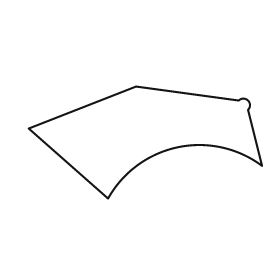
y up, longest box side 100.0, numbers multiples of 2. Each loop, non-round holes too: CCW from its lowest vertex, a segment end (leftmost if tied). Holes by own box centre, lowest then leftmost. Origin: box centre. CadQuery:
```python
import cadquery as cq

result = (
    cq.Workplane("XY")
    .moveTo(-16.0, -24.0)
    .threePointArc((14.0, -2.0), (50.0, -10.0))
    .lineTo(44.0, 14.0)
    .threePointArc((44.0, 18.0), (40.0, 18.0))
    .lineTo(-4.0, 24.0)
    .lineTo(-50.0, 6.0)
    .close()
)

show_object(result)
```